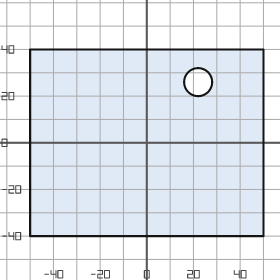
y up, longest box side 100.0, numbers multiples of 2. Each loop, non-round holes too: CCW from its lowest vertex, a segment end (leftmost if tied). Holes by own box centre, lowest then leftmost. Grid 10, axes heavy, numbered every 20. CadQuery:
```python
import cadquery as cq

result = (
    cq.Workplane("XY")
    .moveTo(-50.0, -40.0)
    .lineTo(50.0, -40.0)
    .lineTo(50.0, 40.0)
    .lineTo(-50.0, 40.0)
    .close()
    .moveTo(22.0, 26.0)
    .circle(6.0)
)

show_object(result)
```